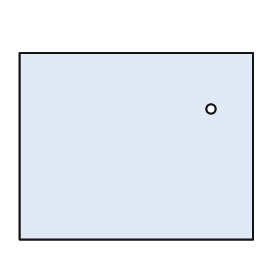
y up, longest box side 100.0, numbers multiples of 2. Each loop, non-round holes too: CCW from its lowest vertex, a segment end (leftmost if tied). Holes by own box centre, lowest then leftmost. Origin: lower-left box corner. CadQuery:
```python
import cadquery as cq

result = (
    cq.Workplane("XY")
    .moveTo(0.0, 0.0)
    .lineTo(100.0, 0.0)
    .lineTo(100.0, 80.0)
    .lineTo(0.0, 80.0)
    .close()
    .moveTo(82.0, 56.0)
    .circle(2.0)
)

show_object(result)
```